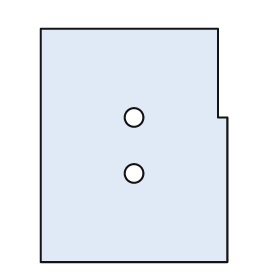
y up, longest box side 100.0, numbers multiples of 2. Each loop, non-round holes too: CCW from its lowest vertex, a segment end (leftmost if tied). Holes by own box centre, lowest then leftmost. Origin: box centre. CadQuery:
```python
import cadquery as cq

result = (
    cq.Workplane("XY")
    .moveTo(-40.0, -50.0)
    .lineTo(40.0, -50.0)
    .lineTo(40.0, 12.0)
    .lineTo(36.0, 12.0)
    .lineTo(36.0, 50.0)
    .lineTo(-40.0, 50.0)
    .close()
    .moveTo(0.0, -12.0)
    .circle(4.0)
    .moveTo(0.0, 12.0)
    .circle(4.0)
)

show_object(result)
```